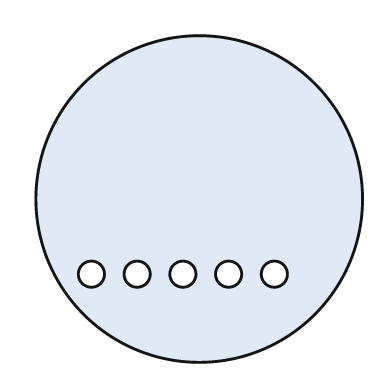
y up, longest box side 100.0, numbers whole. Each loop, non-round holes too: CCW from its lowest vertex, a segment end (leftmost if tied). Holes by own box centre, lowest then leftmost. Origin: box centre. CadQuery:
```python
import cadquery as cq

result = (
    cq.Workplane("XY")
    .moveTo(0.0, 0.0)
    .circle(50.0)
    .moveTo(-33.0, -23.0)
    .circle(4.0)
    .moveTo(-19.0, -23.0)
    .circle(4.0)
    .moveTo(-5.0, -23.0)
    .circle(4.0)
    .moveTo(9.0, -23.0)
    .circle(4.0)
    .moveTo(23.0, -23.0)
    .circle(4.0)
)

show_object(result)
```